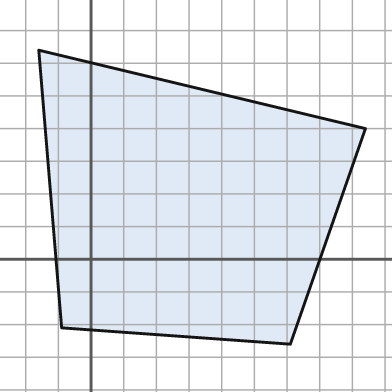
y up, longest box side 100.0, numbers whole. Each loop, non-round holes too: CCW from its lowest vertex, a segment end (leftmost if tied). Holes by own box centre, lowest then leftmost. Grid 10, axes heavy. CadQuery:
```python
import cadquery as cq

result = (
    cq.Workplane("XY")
    .moveTo(61.0, -26.0)
    .lineTo(84.0, 40.0)
    .lineTo(-16.0, 64.0)
    .lineTo(-9.0, -21.0)
    .close()
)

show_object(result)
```